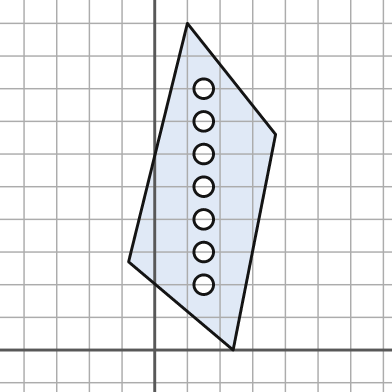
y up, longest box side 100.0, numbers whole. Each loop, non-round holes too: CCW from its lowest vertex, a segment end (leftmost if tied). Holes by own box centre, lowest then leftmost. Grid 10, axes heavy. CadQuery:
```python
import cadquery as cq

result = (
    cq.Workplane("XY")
    .moveTo(24.0, 0.0)
    .lineTo(37.0, 66.0)
    .lineTo(10.0, 100.0)
    .lineTo(-8.0, 27.0)
    .close()
    .moveTo(15.0, 20.0)
    .circle(3.0)
    .moveTo(15.0, 30.0)
    .circle(3.0)
    .moveTo(15.0, 40.0)
    .circle(3.0)
    .moveTo(15.0, 50.0)
    .circle(3.0)
    .moveTo(15.0, 60.0)
    .circle(3.0)
    .moveTo(15.0, 70.0)
    .circle(3.0)
    .moveTo(15.0, 80.0)
    .circle(3.0)
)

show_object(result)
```